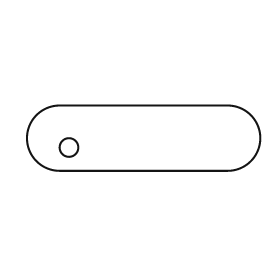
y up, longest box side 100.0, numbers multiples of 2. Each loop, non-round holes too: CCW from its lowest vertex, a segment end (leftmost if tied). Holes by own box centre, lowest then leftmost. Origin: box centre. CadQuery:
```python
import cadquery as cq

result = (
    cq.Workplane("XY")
    .moveTo(-36.0, -14.0)
    .lineTo(36.0, -14.0)
    .threePointArc((50.0, 0.0), (36.0, 14.0))
    .lineTo(-36.0, 14.0)
    .threePointArc((-50.0, 0.0), (-36.0, -14.0))
    .close()
    .moveTo(-32.0, -4.0)
    .circle(4.0)
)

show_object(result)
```